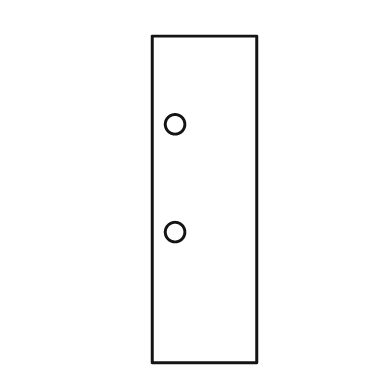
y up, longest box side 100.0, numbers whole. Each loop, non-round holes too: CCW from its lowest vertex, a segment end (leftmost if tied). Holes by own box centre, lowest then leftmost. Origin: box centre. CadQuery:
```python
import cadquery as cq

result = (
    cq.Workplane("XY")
    .moveTo(-16.0, -50.0)
    .lineTo(16.0, -50.0)
    .lineTo(16.0, 50.0)
    .lineTo(-16.0, 50.0)
    .close()
    .moveTo(-9.0, -10.0)
    .circle(3.0)
    .moveTo(-9.0, 23.0)
    .circle(3.0)
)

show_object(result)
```